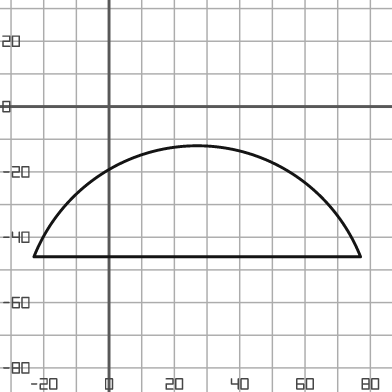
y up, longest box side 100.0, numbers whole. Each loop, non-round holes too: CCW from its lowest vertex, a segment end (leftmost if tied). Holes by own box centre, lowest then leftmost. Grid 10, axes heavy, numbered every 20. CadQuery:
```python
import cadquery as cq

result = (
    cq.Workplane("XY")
    .moveTo(-23.0, -46.0)
    .lineTo(77.0, -46.0)
    .threePointArc((27.0, -12.0), (-23.0, -46.0))
    .close()
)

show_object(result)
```